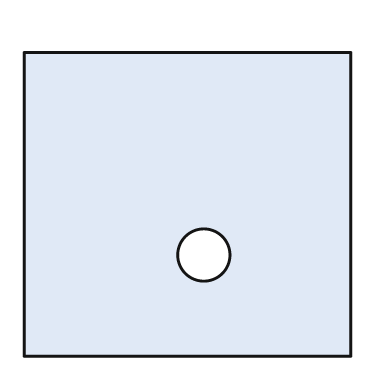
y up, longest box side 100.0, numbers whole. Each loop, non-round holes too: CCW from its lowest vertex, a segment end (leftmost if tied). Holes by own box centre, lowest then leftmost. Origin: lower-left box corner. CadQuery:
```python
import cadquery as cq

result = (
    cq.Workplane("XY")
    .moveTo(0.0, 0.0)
    .lineTo(100.0, 0.0)
    .lineTo(100.0, 93.0)
    .lineTo(0.0, 93.0)
    .close()
    .moveTo(55.0, 31.0)
    .circle(8.0)
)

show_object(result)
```